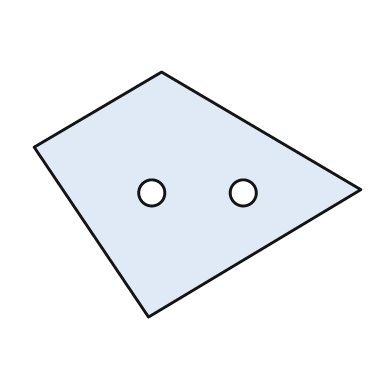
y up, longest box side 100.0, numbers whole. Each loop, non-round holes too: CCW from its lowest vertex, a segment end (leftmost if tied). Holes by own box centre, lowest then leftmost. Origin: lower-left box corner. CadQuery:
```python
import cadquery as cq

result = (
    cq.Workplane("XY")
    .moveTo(35.0, 0.0)
    .lineTo(100.0, 39.0)
    .lineTo(39.0, 75.0)
    .lineTo(0.0, 52.0)
    .close()
    .moveTo(36.0, 38.0)
    .circle(4.0)
    .moveTo(64.0, 38.0)
    .circle(4.0)
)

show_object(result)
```